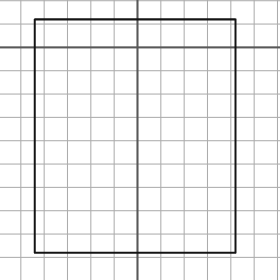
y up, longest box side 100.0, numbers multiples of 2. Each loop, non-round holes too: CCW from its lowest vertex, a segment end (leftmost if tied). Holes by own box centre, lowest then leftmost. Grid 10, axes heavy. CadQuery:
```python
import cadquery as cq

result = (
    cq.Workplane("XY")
    .moveTo(-44.0, -88.0)
    .lineTo(42.0, -88.0)
    .lineTo(42.0, 12.0)
    .lineTo(-44.0, 12.0)
    .close()
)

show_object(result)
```